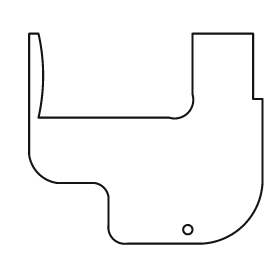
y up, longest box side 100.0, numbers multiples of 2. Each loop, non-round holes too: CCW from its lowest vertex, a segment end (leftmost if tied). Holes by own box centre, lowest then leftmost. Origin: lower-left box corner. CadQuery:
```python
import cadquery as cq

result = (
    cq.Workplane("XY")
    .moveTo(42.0, 0.0)
    .lineTo(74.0, 0.0)
    .threePointArc((92.0, 8.0), (100.0, 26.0))
    .lineTo(100.0, 62.0)
    .lineTo(96.0, 62.0)
    .lineTo(96.0, 90.0)
    .lineTo(70.0, 90.0)
    .lineTo(70.0, 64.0)
    .threePointArc((68.0, 56.0), (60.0, 54.0))
    .lineTo(4.0, 54.0)
    .threePointArc((6.0, 72.0), (4.0, 90.0))
    .lineTo(0.0, 90.0)
    .lineTo(0.0, 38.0)
    .threePointArc((4.0, 30.0), (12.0, 26.0))
    .lineTo(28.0, 26.0)
    .threePointArc((32.0, 24.0), (34.0, 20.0))
    .lineTo(34.0, 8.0)
    .threePointArc((36.0, 2.0), (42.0, 0.0))
    .close()
    .moveTo(68.0, 6.0)
    .circle(2.0)
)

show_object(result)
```